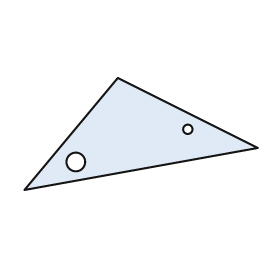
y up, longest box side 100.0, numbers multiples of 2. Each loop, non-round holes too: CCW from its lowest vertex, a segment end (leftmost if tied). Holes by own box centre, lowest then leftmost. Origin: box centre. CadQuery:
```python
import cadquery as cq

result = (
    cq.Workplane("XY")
    .moveTo(-50.0, -24.0)
    .lineTo(50.0, -6.0)
    .lineTo(-10.0, 24.0)
    .close()
    .moveTo(-28.0, -12.0)
    .circle(4.0)
    .moveTo(20.0, 2.0)
    .circle(2.0)
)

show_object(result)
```